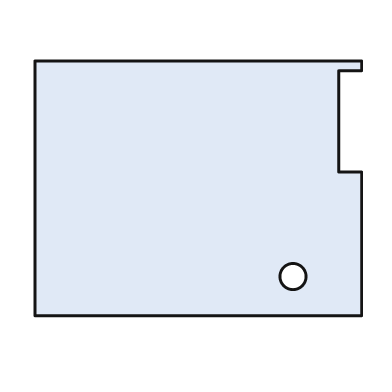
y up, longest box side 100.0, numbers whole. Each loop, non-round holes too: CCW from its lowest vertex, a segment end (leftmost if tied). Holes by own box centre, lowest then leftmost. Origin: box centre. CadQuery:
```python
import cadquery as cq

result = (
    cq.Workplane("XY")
    .moveTo(-50.0, -39.0)
    .lineTo(50.0, -39.0)
    .lineTo(50.0, 5.0)
    .lineTo(43.0, 5.0)
    .lineTo(43.0, 36.0)
    .lineTo(50.0, 36.0)
    .lineTo(50.0, 39.0)
    .lineTo(-50.0, 39.0)
    .close()
    .moveTo(29.0, -27.0)
    .circle(4.0)
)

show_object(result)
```